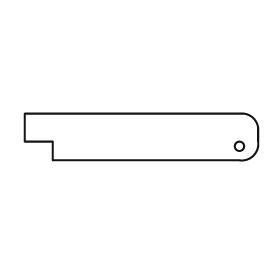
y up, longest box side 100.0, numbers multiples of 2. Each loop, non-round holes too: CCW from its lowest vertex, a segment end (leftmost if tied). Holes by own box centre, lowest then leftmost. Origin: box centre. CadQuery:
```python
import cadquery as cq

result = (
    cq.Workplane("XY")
    .moveTo(-38.0, -10.0)
    .lineTo(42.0, -10.0)
    .threePointArc((48.0, -8.0), (50.0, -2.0))
    .lineTo(50.0, 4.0)
    .threePointArc((48.0, 8.0), (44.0, 10.0))
    .lineTo(-50.0, 10.0)
    .lineTo(-50.0, -2.0)
    .lineTo(-38.0, -2.0)
    .close()
    .moveTo(42.0, -4.0)
    .circle(2.0)
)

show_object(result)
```